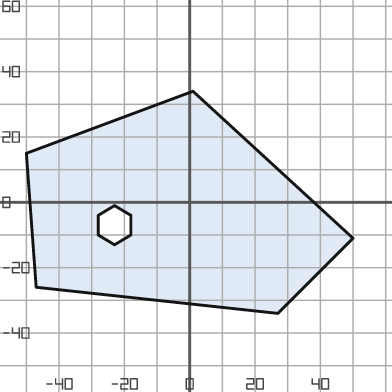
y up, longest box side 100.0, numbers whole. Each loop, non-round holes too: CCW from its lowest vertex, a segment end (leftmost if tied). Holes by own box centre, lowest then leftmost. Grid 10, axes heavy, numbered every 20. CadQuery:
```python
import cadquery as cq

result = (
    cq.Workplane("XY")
    .moveTo(27.0, -34.0)
    .lineTo(50.0, -11.0)
    .lineTo(1.0, 34.0)
    .lineTo(-50.0, 15.0)
    .lineTo(-47.0, -26.0)
    .close()
    .moveTo(-23.0, -13.0)
    .lineTo(-18.0, -10.0)
    .lineTo(-18.0, -4.0)
    .lineTo(-23.0, -1.0)
    .lineTo(-28.0, -4.0)
    .lineTo(-28.0, -10.0)
    .close()
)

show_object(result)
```